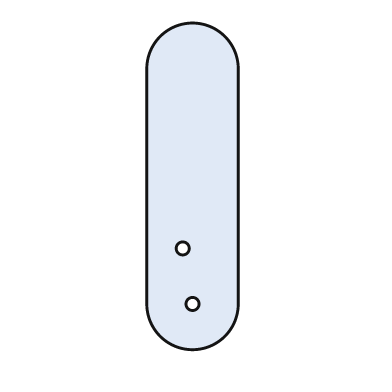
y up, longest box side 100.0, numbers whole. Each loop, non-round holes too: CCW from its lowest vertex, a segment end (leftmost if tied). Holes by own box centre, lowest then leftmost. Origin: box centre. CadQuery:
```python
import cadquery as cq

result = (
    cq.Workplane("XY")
    .moveTo(-14.0, -36.0)
    .threePointArc((0.0, -50.0), (14.0, -36.0))
    .lineTo(14.0, 36.0)
    .threePointArc((0.0, 50.0), (-14.0, 36.0))
    .close()
    .moveTo(0.0, -36.0)
    .circle(2.0)
    .moveTo(-3.0, -19.0)
    .circle(2.0)
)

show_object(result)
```